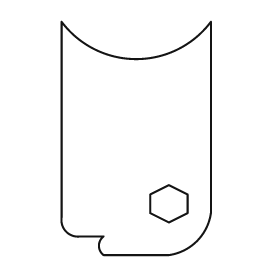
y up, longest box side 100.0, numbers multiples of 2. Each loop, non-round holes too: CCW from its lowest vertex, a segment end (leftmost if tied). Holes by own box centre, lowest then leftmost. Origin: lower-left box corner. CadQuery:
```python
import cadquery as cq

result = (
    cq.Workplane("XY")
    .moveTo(18.0, 0.0)
    .lineTo(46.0, 0.0)
    .threePointArc((58.0, 6.0), (64.0, 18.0))
    .lineTo(64.0, 100.0)
    .threePointArc((32.0, 84.0), (0.0, 100.0))
    .lineTo(0.0, 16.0)
    .threePointArc((2.0, 10.0), (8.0, 8.0))
    .lineTo(18.0, 8.0)
    .threePointArc((16.0, 4.0), (18.0, 0.0))
    .close()
    .moveTo(46.0, 14.0)
    .lineTo(54.0, 18.0)
    .lineTo(54.0, 26.0)
    .lineTo(46.0, 30.0)
    .lineTo(38.0, 26.0)
    .lineTo(38.0, 18.0)
    .close()
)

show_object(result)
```